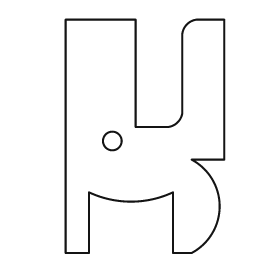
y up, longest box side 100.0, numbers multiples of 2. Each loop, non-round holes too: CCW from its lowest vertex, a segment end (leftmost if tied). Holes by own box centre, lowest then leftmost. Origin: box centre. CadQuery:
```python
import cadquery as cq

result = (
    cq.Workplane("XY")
    .moveTo(-34.0, -50.0)
    .lineTo(-24.0, -50.0)
    .lineTo(-24.0, -24.0)
    .threePointArc((-6.0, -28.0), (12.0, -24.0))
    .lineTo(12.0, -50.0)
    .lineTo(20.0, -50.0)
    .threePointArc((32.0, -30.0), (20.0, -10.0))
    .lineTo(34.0, -10.0)
    .lineTo(34.0, 50.0)
    .lineTo(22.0, 50.0)
    .threePointArc((18.0, 48.0), (16.0, 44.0))
    .lineTo(16.0, 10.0)
    .threePointArc((14.0, 6.0), (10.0, 4.0))
    .lineTo(-4.0, 4.0)
    .lineTo(-4.0, 50.0)
    .lineTo(-34.0, 50.0)
    .close()
    .moveTo(-14.0, -2.0)
    .circle(4.0)
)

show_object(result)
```